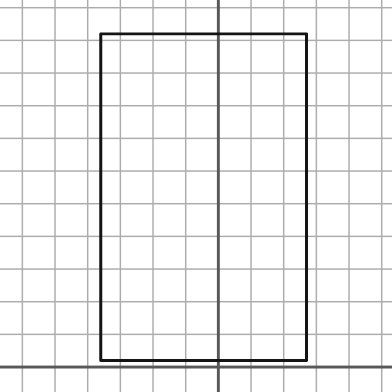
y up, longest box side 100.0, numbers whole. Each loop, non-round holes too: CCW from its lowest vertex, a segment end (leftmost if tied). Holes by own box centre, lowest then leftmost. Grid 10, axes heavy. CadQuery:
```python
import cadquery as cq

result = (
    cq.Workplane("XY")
    .moveTo(-36.0, 2.0)
    .lineTo(27.0, 2.0)
    .lineTo(27.0, 102.0)
    .lineTo(-36.0, 102.0)
    .close()
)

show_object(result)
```